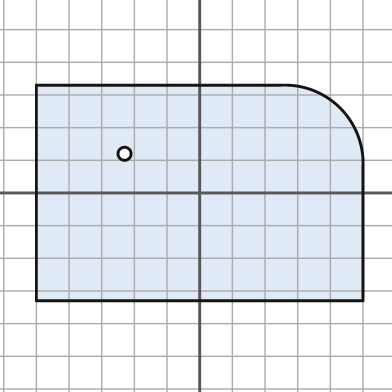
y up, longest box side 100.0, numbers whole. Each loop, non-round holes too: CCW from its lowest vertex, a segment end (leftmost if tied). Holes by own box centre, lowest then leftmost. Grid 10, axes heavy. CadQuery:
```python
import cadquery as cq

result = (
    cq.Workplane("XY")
    .moveTo(-50.0, -33.0)
    .lineTo(50.0, -33.0)
    .lineTo(50.0, 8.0)
    .threePointArc((43.0, 26.0), (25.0, 33.0))
    .lineTo(-50.0, 33.0)
    .close()
    .moveTo(-23.0, 12.0)
    .circle(2.0)
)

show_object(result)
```